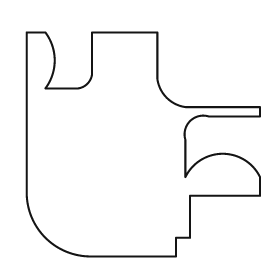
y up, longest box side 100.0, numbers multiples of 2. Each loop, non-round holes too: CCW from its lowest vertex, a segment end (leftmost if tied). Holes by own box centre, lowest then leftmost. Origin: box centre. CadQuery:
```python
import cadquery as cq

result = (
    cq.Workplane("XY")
    .moveTo(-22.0, -48.0)
    .lineTo(14.0, -48.0)
    .lineTo(14.0, -40.0)
    .lineTo(20.0, -40.0)
    .lineTo(20.0, -22.0)
    .lineTo(50.0, -22.0)
    .lineTo(50.0, -14.0)
    .threePointArc((34.0, -4.0), (18.0, -14.0))
    .lineTo(18.0, 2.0)
    .threePointArc((20.0, 10.0), (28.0, 12.0))
    .lineTo(50.0, 12.0)
    .lineTo(50.0, 16.0)
    .lineTo(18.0, 16.0)
    .threePointArc((10.0, 20.0), (6.0, 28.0))
    .lineTo(6.0, 48.0)
    .lineTo(-22.0, 48.0)
    .lineTo(-22.0, 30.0)
    .threePointArc((-24.0, 26.0), (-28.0, 24.0))
    .lineTo(-42.0, 24.0)
    .threePointArc((-38.0, 36.0), (-42.0, 48.0))
    .lineTo(-50.0, 48.0)
    .lineTo(-50.0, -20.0)
    .threePointArc((-42.0, -40.0), (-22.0, -48.0))
    .close()
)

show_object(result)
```